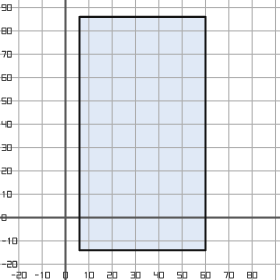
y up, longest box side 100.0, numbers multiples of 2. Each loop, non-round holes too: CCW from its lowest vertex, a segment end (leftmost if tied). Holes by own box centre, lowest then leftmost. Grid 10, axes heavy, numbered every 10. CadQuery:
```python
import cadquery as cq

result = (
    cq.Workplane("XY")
    .moveTo(6.0, -14.0)
    .lineTo(60.0, -14.0)
    .lineTo(60.0, 86.0)
    .lineTo(6.0, 86.0)
    .close()
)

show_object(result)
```